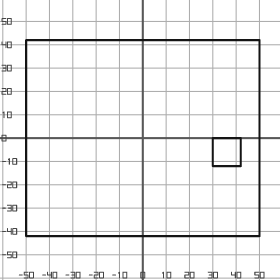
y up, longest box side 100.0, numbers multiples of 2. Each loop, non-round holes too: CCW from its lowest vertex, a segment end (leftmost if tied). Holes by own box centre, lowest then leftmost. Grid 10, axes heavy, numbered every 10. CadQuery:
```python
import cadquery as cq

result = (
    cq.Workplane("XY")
    .moveTo(-50.0, -42.0)
    .lineTo(50.0, -42.0)
    .lineTo(50.0, 42.0)
    .lineTo(-50.0, 42.0)
    .close()
    .moveTo(30.0, -12.0)
    .lineTo(42.0, -12.0)
    .lineTo(42.0, 0.0)
    .lineTo(30.0, 0.0)
    .close()
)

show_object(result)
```